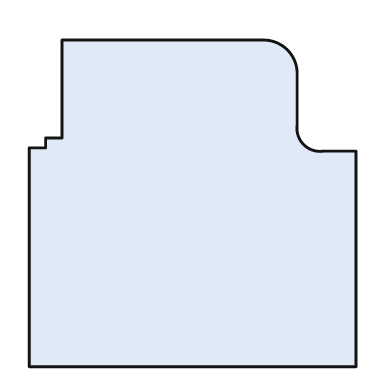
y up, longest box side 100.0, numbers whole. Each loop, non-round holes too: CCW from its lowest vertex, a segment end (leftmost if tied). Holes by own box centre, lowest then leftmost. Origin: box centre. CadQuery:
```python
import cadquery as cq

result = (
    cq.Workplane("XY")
    .moveTo(-50.0, -50.0)
    .lineTo(50.0, -50.0)
    .lineTo(50.0, 16.0)
    .lineTo(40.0, 16.0)
    .threePointArc((34.0, 18.0), (32.0, 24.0))
    .lineTo(32.0, 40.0)
    .threePointArc((29.0, 47.0), (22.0, 50.0))
    .lineTo(-40.0, 50.0)
    .lineTo(-40.0, 20.0)
    .lineTo(-45.0, 20.0)
    .lineTo(-45.0, 17.0)
    .lineTo(-50.0, 17.0)
    .close()
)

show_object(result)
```